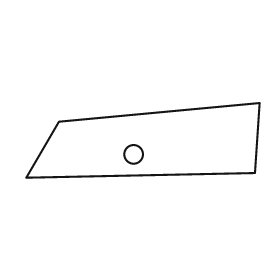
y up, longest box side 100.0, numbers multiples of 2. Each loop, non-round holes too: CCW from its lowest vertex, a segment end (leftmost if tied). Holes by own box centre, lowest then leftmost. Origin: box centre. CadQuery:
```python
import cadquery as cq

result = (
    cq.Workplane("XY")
    .moveTo(-50.0, -16.0)
    .lineTo(48.0, -14.0)
    .lineTo(50.0, 16.0)
    .lineTo(-36.0, 8.0)
    .close()
    .moveTo(-4.0, -6.0)
    .circle(4.0)
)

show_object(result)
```